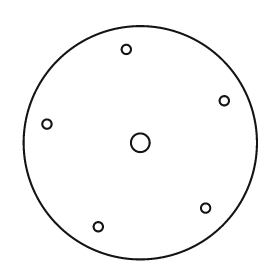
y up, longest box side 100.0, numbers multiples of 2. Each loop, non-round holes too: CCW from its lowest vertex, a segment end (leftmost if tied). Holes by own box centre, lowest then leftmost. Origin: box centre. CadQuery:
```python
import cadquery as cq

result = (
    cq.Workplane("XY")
    .moveTo(0.0, 0.0)
    .circle(50.0)
    .moveTo(-18.0, -36.0)
    .circle(2.0)
    .moveTo(28.0, -28.0)
    .circle(2.0)
    .moveTo(0.0, 0.0)
    .circle(4.0)
    .moveTo(-40.0, 8.0)
    .circle(2.0)
    .moveTo(36.0, 18.0)
    .circle(2.0)
    .moveTo(-6.0, 40.0)
    .circle(2.0)
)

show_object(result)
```